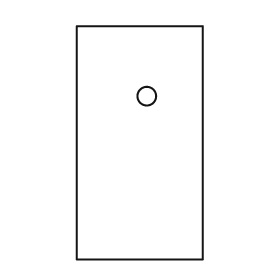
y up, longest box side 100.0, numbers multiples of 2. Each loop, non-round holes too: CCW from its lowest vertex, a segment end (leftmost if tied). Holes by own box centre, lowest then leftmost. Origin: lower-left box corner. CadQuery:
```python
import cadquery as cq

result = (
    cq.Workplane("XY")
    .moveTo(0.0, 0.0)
    .lineTo(54.0, 0.0)
    .lineTo(54.0, 100.0)
    .lineTo(0.0, 100.0)
    .close()
    .moveTo(30.0, 70.0)
    .circle(4.0)
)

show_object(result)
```